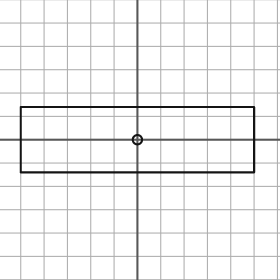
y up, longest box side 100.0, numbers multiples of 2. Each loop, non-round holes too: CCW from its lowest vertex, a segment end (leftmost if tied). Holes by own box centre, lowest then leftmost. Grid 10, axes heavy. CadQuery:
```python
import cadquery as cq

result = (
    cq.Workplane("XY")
    .moveTo(-50.0, -14.0)
    .lineTo(50.0, -14.0)
    .lineTo(50.0, 14.0)
    .lineTo(-50.0, 14.0)
    .close()
    .moveTo(0.0, 0.0)
    .circle(2.0)
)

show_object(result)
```